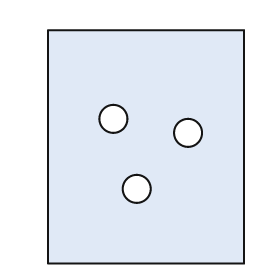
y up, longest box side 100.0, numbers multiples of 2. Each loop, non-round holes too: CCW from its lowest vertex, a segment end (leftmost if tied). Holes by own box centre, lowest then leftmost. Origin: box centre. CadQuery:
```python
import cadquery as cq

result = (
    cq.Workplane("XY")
    .moveTo(-42.0, -50.0)
    .lineTo(42.0, -50.0)
    .lineTo(42.0, 50.0)
    .lineTo(-42.0, 50.0)
    .close()
    .moveTo(-4.0, -18.0)
    .circle(6.0)
    .moveTo(18.0, 6.0)
    .circle(6.0)
    .moveTo(-14.0, 12.0)
    .circle(6.0)
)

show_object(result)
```